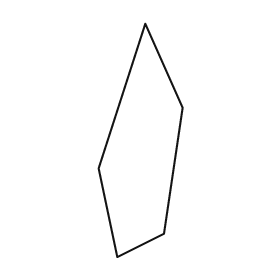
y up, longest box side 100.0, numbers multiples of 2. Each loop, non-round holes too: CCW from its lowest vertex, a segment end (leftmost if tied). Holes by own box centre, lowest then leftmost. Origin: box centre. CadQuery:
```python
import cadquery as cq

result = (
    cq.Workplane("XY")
    .moveTo(-10.0, -50.0)
    .lineTo(10.0, -40.0)
    .lineTo(18.0, 14.0)
    .lineTo(2.0, 50.0)
    .lineTo(-18.0, -12.0)
    .close()
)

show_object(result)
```